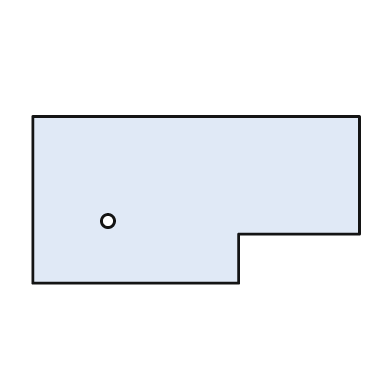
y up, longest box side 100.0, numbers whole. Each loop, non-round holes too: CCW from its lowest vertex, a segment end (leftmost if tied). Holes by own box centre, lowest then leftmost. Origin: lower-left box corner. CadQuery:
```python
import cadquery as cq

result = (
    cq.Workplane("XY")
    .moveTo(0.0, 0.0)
    .lineTo(63.0, 0.0)
    .lineTo(63.0, 15.0)
    .lineTo(100.0, 15.0)
    .lineTo(100.0, 51.0)
    .lineTo(0.0, 51.0)
    .close()
    .moveTo(23.0, 19.0)
    .circle(2.0)
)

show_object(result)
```